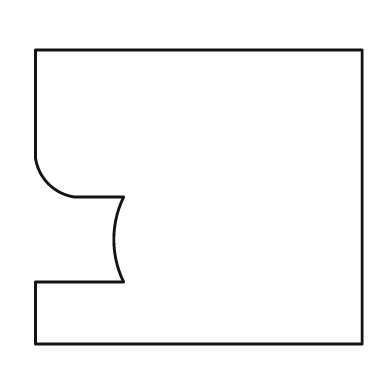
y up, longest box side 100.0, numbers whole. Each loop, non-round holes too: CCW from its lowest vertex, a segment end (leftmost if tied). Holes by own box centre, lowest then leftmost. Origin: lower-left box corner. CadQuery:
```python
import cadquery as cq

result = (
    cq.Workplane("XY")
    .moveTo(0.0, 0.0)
    .lineTo(100.0, 0.0)
    .lineTo(100.0, 90.0)
    .lineTo(0.0, 90.0)
    .lineTo(0.0, 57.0)
    .threePointArc((4.0, 49.0), (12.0, 45.0))
    .lineTo(27.0, 45.0)
    .threePointArc((24.0, 32.0), (27.0, 19.0))
    .lineTo(0.0, 19.0)
    .close()
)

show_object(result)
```